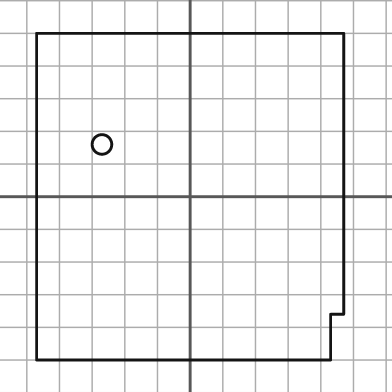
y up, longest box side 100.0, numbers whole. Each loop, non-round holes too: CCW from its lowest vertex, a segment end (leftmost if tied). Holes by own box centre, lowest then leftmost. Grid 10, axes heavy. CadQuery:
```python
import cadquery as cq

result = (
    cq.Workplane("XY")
    .moveTo(-47.0, -50.0)
    .lineTo(43.0, -50.0)
    .lineTo(43.0, -36.0)
    .lineTo(47.0, -36.0)
    .lineTo(47.0, 50.0)
    .lineTo(-47.0, 50.0)
    .close()
    .moveTo(-27.0, 16.0)
    .circle(3.0)
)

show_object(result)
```